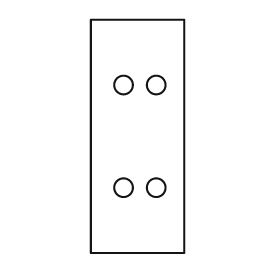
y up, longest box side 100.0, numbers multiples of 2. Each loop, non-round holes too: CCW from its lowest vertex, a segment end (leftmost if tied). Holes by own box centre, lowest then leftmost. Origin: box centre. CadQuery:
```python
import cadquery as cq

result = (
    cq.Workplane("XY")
    .moveTo(-20.0, -50.0)
    .lineTo(20.0, -50.0)
    .lineTo(20.0, 50.0)
    .lineTo(-20.0, 50.0)
    .close()
    .moveTo(-6.0, -22.0)
    .circle(4.0)
    .moveTo(8.0, -22.0)
    .circle(4.0)
    .moveTo(-6.0, 22.0)
    .circle(4.0)
    .moveTo(8.0, 22.0)
    .circle(4.0)
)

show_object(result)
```